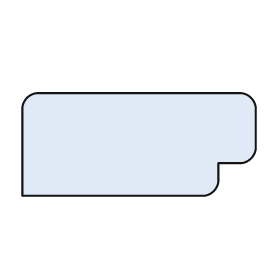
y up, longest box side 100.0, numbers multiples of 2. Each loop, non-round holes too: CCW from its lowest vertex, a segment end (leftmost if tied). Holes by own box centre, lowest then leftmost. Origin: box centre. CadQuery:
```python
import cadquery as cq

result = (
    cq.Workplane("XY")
    .moveTo(-50.0, -22.0)
    .lineTo(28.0, -22.0)
    .threePointArc((32.0, -20.0), (34.0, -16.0))
    .lineTo(34.0, -8.0)
    .lineTo(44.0, -8.0)
    .threePointArc((48.0, -6.0), (50.0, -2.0))
    .lineTo(50.0, 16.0)
    .threePointArc((48.0, 20.0), (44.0, 22.0))
    .lineTo(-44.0, 22.0)
    .threePointArc((-48.0, 20.0), (-50.0, 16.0))
    .close()
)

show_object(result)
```